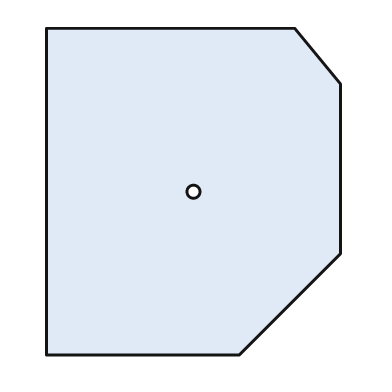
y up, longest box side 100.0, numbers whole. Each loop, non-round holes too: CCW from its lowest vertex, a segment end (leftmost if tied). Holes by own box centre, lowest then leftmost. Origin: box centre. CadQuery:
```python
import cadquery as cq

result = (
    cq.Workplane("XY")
    .moveTo(-45.0, -50.0)
    .lineTo(14.0, -50.0)
    .lineTo(45.0, -19.0)
    .lineTo(45.0, 33.0)
    .lineTo(31.0, 50.0)
    .lineTo(-45.0, 50.0)
    .close()
    .moveTo(0.0, 0.0)
    .circle(2.0)
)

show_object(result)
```